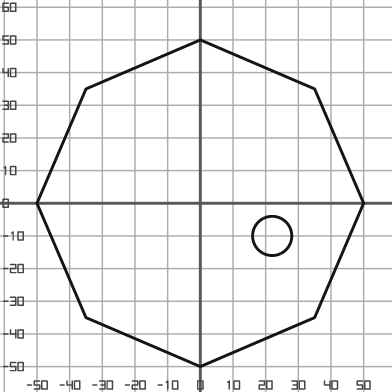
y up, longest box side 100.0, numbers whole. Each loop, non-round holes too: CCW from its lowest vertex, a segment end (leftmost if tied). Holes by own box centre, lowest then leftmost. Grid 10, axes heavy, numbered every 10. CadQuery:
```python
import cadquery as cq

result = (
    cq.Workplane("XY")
    .moveTo(0.0, -50.0)
    .lineTo(35.0, -35.0)
    .lineTo(50.0, 0.0)
    .lineTo(35.0, 35.0)
    .lineTo(0.0, 50.0)
    .lineTo(-35.0, 35.0)
    .lineTo(-50.0, 0.0)
    .lineTo(-35.0, -35.0)
    .close()
    .moveTo(22.0, -10.0)
    .circle(6.0)
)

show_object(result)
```